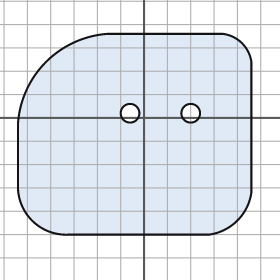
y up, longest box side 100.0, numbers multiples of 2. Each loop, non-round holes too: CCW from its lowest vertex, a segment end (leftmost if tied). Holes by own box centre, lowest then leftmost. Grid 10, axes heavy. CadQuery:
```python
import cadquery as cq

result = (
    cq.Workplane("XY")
    .moveTo(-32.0, -50.0)
    .lineTo(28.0, -50.0)
    .threePointArc((40.0, -44.0), (46.0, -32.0))
    .lineTo(46.0, 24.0)
    .threePointArc((42.0, 32.0), (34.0, 36.0))
    .lineTo(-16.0, 36.0)
    .threePointArc((-42.0, 24.0), (-54.0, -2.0))
    .lineTo(-54.0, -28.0)
    .threePointArc((-48.0, -44.0), (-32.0, -50.0))
    .close()
    .moveTo(-6.0, 2.0)
    .circle(4.0)
    .moveTo(20.0, 2.0)
    .circle(4.0)
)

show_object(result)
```